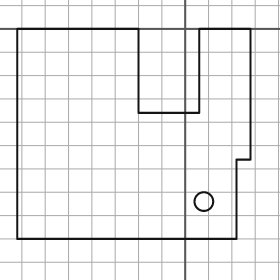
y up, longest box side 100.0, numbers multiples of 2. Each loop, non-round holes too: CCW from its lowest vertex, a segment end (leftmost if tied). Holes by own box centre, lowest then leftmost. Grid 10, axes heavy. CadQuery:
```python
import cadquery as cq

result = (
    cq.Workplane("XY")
    .moveTo(-72.0, -90.0)
    .lineTo(22.0, -90.0)
    .lineTo(22.0, -56.0)
    .lineTo(28.0, -56.0)
    .lineTo(28.0, 0.0)
    .lineTo(6.0, 0.0)
    .lineTo(6.0, -36.0)
    .lineTo(-20.0, -36.0)
    .lineTo(-20.0, 0.0)
    .lineTo(-72.0, 0.0)
    .close()
    .moveTo(8.0, -74.0)
    .circle(4.0)
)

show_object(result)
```